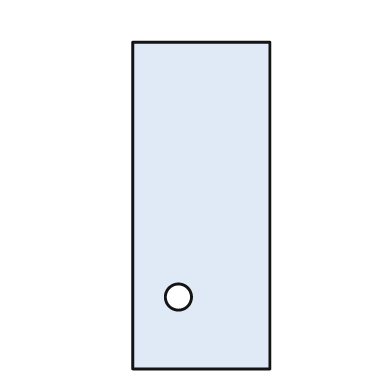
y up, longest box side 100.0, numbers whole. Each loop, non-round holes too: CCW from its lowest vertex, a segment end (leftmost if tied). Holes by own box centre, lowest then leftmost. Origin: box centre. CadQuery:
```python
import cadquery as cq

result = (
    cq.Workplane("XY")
    .moveTo(-21.0, -50.0)
    .lineTo(21.0, -50.0)
    .lineTo(21.0, 50.0)
    .lineTo(-21.0, 50.0)
    .close()
    .moveTo(-7.0, -28.0)
    .circle(4.0)
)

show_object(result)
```